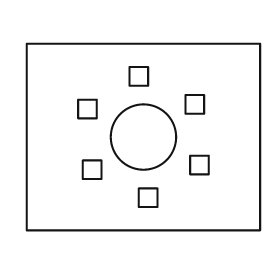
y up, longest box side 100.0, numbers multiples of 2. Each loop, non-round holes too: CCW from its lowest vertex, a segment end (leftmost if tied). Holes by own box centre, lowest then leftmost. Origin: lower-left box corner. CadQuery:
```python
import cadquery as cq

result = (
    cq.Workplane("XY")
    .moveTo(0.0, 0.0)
    .lineTo(100.0, 0.0)
    .lineTo(100.0, 80.0)
    .lineTo(0.0, 80.0)
    .close()
    .moveTo(48.0, 10.0)
    .lineTo(56.0, 10.0)
    .lineTo(56.0, 18.0)
    .lineTo(48.0, 18.0)
    .close()
    .moveTo(24.0, 22.0)
    .lineTo(32.0, 22.0)
    .lineTo(32.0, 30.0)
    .lineTo(24.0, 30.0)
    .close()
    .moveTo(70.0, 24.0)
    .lineTo(78.0, 24.0)
    .lineTo(78.0, 32.0)
    .lineTo(70.0, 32.0)
    .close()
    .moveTo(50.0, 40.0)
    .circle(14.0)
    .moveTo(22.0, 48.0)
    .lineTo(30.0, 48.0)
    .lineTo(30.0, 56.0)
    .lineTo(22.0, 56.0)
    .close()
    .moveTo(68.0, 50.0)
    .lineTo(76.0, 50.0)
    .lineTo(76.0, 58.0)
    .lineTo(68.0, 58.0)
    .close()
    .moveTo(44.0, 62.0)
    .lineTo(52.0, 62.0)
    .lineTo(52.0, 70.0)
    .lineTo(44.0, 70.0)
    .close()
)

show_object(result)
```